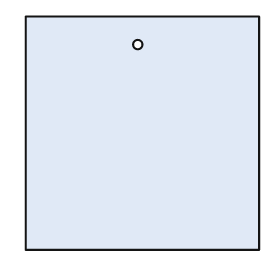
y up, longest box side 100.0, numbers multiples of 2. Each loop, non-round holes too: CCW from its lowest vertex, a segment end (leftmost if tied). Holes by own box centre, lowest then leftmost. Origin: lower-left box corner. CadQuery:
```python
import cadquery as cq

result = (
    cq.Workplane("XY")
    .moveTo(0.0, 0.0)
    .lineTo(100.0, 0.0)
    .lineTo(100.0, 100.0)
    .lineTo(0.0, 100.0)
    .close()
    .moveTo(48.0, 88.0)
    .circle(2.0)
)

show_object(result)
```